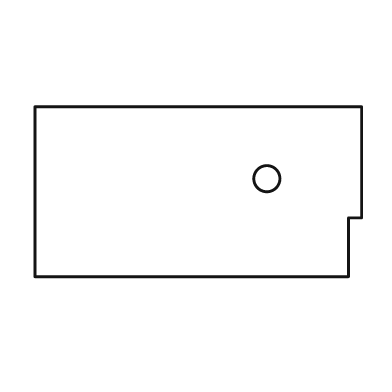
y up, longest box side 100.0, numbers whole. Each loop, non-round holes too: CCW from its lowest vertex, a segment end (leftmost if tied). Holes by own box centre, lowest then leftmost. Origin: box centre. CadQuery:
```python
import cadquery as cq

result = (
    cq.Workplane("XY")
    .moveTo(-50.0, -26.0)
    .lineTo(46.0, -26.0)
    .lineTo(46.0, -8.0)
    .lineTo(50.0, -8.0)
    .lineTo(50.0, 26.0)
    .lineTo(-50.0, 26.0)
    .close()
    .moveTo(21.0, 4.0)
    .circle(4.0)
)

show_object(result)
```